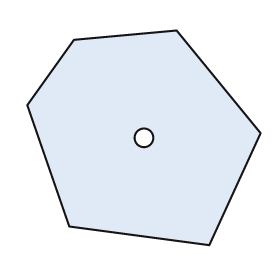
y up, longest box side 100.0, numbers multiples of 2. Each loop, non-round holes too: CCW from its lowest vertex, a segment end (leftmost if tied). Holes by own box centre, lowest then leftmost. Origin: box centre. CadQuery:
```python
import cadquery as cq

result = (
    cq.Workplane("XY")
    .moveTo(28.0, -46.0)
    .lineTo(50.0, 2.0)
    .lineTo(14.0, 46.0)
    .lineTo(-30.0, 42.0)
    .lineTo(-50.0, 14.0)
    .lineTo(-32.0, -38.0)
    .close()
    .moveTo(0.0, 0.0)
    .circle(4.0)
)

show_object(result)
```